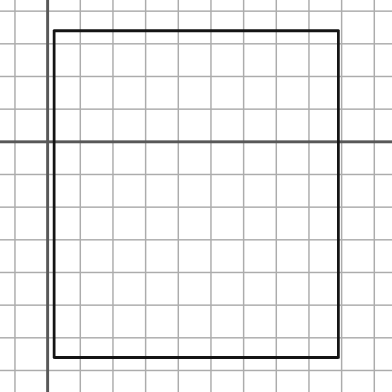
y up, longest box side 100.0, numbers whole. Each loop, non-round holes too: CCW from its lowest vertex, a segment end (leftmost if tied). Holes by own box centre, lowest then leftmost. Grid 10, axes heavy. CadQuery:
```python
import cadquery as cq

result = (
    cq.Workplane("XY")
    .moveTo(2.0, -66.0)
    .lineTo(89.0, -66.0)
    .lineTo(89.0, 34.0)
    .lineTo(2.0, 34.0)
    .close()
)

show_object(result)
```